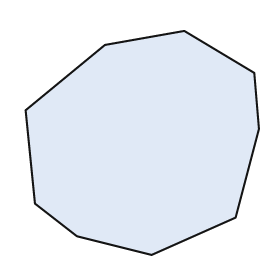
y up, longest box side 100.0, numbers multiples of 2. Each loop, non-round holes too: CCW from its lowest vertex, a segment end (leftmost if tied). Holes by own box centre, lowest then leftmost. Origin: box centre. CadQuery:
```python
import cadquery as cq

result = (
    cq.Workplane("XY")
    .moveTo(4.0, -48.0)
    .lineTo(40.0, -32.0)
    .lineTo(50.0, 6.0)
    .lineTo(48.0, 30.0)
    .lineTo(18.0, 48.0)
    .lineTo(-16.0, 42.0)
    .lineTo(-50.0, 14.0)
    .lineTo(-46.0, -26.0)
    .lineTo(-28.0, -40.0)
    .close()
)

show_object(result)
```